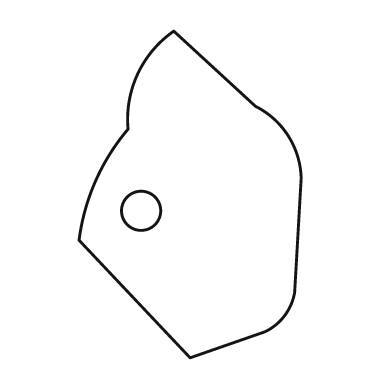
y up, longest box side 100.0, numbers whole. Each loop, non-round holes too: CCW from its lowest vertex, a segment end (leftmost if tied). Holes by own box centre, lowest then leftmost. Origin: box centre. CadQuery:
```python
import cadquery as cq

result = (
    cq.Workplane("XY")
    .moveTo(0.0, -50.0)
    .lineTo(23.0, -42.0)
    .threePointArc((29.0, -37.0), (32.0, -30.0))
    .lineTo(34.0, 5.0)
    .threePointArc((30.0, 18.0), (20.0, 27.0))
    .lineTo(-5.0, 50.0)
    .threePointArc((-16.0, 37.0), (-19.0, 20.0))
    .threePointArc((-29.0, 4.0), (-34.0, -14.0))
    .close()
    .moveTo(-15.0, -5.0)
    .circle(6.0)
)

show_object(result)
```